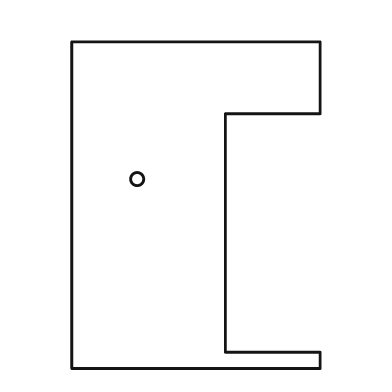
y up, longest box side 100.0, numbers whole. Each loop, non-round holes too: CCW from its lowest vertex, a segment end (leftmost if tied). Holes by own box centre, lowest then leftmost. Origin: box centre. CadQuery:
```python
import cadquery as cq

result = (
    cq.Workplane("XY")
    .moveTo(-38.0, -50.0)
    .lineTo(38.0, -50.0)
    .lineTo(38.0, -45.0)
    .lineTo(9.0, -45.0)
    .lineTo(9.0, 28.0)
    .lineTo(38.0, 28.0)
    .lineTo(38.0, 50.0)
    .lineTo(-38.0, 50.0)
    .close()
    .moveTo(-18.0, 8.0)
    .circle(2.0)
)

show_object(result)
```